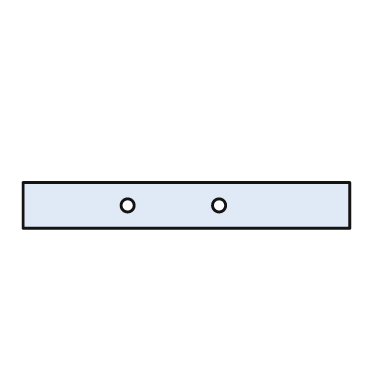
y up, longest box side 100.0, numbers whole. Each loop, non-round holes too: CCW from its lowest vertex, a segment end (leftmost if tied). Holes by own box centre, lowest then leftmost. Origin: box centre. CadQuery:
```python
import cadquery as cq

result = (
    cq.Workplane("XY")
    .moveTo(-50.0, -7.0)
    .lineTo(50.0, -7.0)
    .lineTo(50.0, 7.0)
    .lineTo(-50.0, 7.0)
    .close()
    .moveTo(-18.0, 0.0)
    .circle(2.0)
    .moveTo(10.0, 0.0)
    .circle(2.0)
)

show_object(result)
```